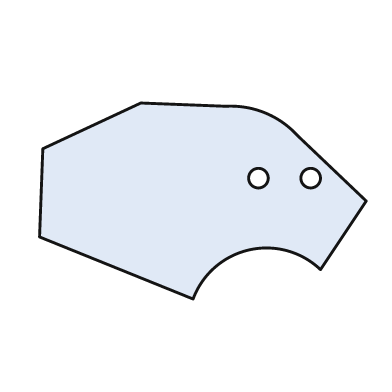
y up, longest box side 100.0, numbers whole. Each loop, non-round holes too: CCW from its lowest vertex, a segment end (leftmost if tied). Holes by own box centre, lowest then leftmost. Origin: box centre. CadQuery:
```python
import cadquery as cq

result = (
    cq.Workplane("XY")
    .moveTo(-3.0, -30.0)
    .threePointArc((14.0, -15.0), (36.0, -21.0))
    .lineTo(50.0, 0.0)
    .lineTo(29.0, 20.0)
    .threePointArc((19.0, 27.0), (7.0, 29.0))
    .lineTo(-19.0, 30.0)
    .lineTo(-49.0, 16.0)
    .lineTo(-50.0, -11.0)
    .close()
    .moveTo(17.0, 7.0)
    .circle(3.0)
    .moveTo(33.0, 7.0)
    .circle(3.0)
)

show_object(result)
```